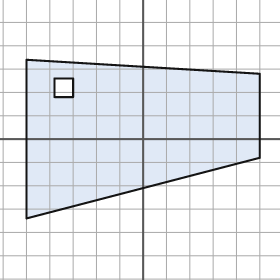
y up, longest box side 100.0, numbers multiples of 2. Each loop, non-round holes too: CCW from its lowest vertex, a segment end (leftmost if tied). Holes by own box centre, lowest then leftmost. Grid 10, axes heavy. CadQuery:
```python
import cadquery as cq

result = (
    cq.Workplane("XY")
    .moveTo(-50.0, -34.0)
    .lineTo(50.0, -8.0)
    .lineTo(50.0, 28.0)
    .lineTo(-50.0, 34.0)
    .close()
    .moveTo(-38.0, 18.0)
    .lineTo(-30.0, 18.0)
    .lineTo(-30.0, 26.0)
    .lineTo(-38.0, 26.0)
    .close()
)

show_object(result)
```